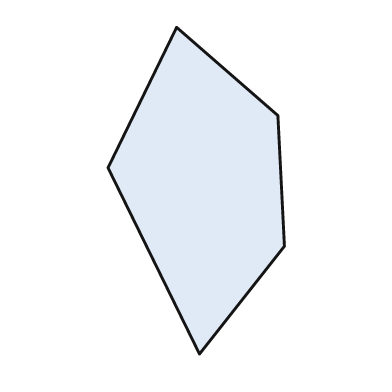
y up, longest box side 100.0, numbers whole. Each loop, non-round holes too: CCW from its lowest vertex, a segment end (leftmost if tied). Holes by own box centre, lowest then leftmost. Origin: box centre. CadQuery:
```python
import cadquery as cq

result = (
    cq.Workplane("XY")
    .moveTo(1.0, -50.0)
    .lineTo(27.0, -17.0)
    .lineTo(25.0, 23.0)
    .lineTo(-6.0, 50.0)
    .lineTo(-27.0, 7.0)
    .close()
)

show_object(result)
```